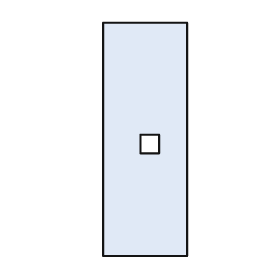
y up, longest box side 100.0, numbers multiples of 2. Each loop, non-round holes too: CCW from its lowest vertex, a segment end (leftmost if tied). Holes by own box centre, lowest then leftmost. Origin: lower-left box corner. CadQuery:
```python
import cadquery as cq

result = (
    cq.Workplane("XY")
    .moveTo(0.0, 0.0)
    .lineTo(36.0, 0.0)
    .lineTo(36.0, 100.0)
    .lineTo(0.0, 100.0)
    .close()
    .moveTo(16.0, 44.0)
    .lineTo(24.0, 44.0)
    .lineTo(24.0, 52.0)
    .lineTo(16.0, 52.0)
    .close()
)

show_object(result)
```